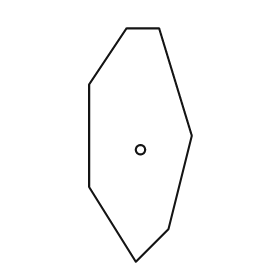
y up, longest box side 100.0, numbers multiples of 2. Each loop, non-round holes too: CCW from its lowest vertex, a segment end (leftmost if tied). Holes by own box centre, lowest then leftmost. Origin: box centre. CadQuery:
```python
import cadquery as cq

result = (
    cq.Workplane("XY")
    .moveTo(-2.0, -50.0)
    .lineTo(12.0, -36.0)
    .lineTo(22.0, 4.0)
    .lineTo(8.0, 50.0)
    .lineTo(-6.0, 50.0)
    .lineTo(-22.0, 26.0)
    .lineTo(-22.0, -18.0)
    .close()
    .moveTo(0.0, -2.0)
    .circle(2.0)
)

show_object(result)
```